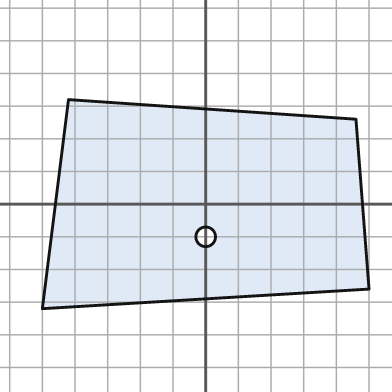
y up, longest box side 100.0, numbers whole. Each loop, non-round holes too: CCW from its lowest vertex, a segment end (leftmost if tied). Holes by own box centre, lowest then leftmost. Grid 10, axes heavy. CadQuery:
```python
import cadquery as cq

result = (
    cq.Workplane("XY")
    .moveTo(-50.0, -32.0)
    .lineTo(50.0, -26.0)
    .lineTo(46.0, 26.0)
    .lineTo(-42.0, 32.0)
    .close()
    .moveTo(0.0, -10.0)
    .circle(3.0)
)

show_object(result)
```